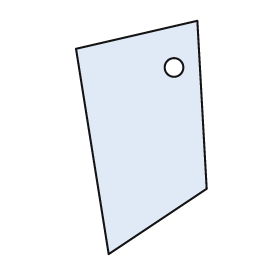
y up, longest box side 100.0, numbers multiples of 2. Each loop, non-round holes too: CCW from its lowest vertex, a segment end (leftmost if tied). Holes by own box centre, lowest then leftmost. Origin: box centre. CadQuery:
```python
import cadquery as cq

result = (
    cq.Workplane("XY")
    .moveTo(-14.0, -50.0)
    .lineTo(28.0, -22.0)
    .lineTo(24.0, 50.0)
    .lineTo(-28.0, 38.0)
    .close()
    .moveTo(14.0, 30.0)
    .circle(4.0)
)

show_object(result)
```